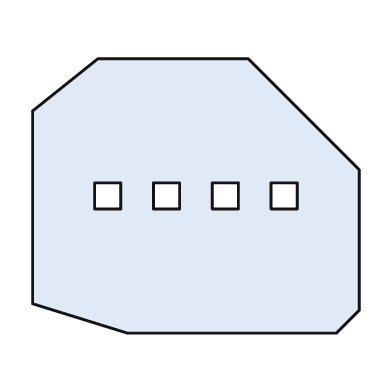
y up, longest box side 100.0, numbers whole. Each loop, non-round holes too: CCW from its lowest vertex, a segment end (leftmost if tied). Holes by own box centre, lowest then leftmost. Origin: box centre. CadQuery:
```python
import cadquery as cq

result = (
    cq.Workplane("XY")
    .moveTo(-21.0, -42.0)
    .lineTo(43.0, -42.0)
    .lineTo(50.0, -35.0)
    .lineTo(50.0, 8.0)
    .lineTo(16.0, 42.0)
    .lineTo(-30.0, 42.0)
    .lineTo(-50.0, 26.0)
    .lineTo(-50.0, -33.0)
    .close()
    .moveTo(-31.0, -4.0)
    .lineTo(-23.0, -4.0)
    .lineTo(-23.0, 4.0)
    .lineTo(-31.0, 4.0)
    .close()
    .moveTo(-13.0, -4.0)
    .lineTo(-5.0, -4.0)
    .lineTo(-5.0, 4.0)
    .lineTo(-13.0, 4.0)
    .close()
    .moveTo(5.0, -4.0)
    .lineTo(13.0, -4.0)
    .lineTo(13.0, 4.0)
    .lineTo(5.0, 4.0)
    .close()
    .moveTo(23.0, -4.0)
    .lineTo(31.0, -4.0)
    .lineTo(31.0, 4.0)
    .lineTo(23.0, 4.0)
    .close()
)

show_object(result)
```